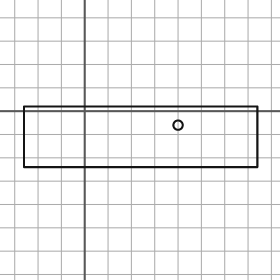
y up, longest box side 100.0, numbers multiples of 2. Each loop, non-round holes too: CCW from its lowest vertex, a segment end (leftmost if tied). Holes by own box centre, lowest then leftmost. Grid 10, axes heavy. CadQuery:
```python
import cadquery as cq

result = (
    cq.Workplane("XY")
    .moveTo(-26.0, -24.0)
    .lineTo(74.0, -24.0)
    .lineTo(74.0, 2.0)
    .lineTo(-26.0, 2.0)
    .close()
    .moveTo(40.0, -6.0)
    .circle(2.0)
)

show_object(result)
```